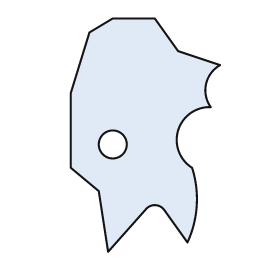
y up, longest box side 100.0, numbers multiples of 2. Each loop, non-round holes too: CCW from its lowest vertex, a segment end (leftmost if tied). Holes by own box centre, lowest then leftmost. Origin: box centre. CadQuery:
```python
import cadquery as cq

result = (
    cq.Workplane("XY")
    .moveTo(-16.0, -50.0)
    .lineTo(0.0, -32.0)
    .threePointArc((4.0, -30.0), (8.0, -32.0))
    .lineTo(18.0, -46.0)
    .threePointArc((22.0, -30.0), (20.0, -14.0))
    .threePointArc((14.0, 2.0), (28.0, 12.0))
    .threePointArc((26.0, 22.0), (32.0, 30.0))
    .lineTo(14.0, 36.0)
    .lineTo(4.0, 50.0)
    .lineTo(-14.0, 50.0)
    .lineTo(-24.0, 44.0)
    .lineTo(-32.0, 18.0)
    .lineTo(-32.0, -14.0)
    .lineTo(-20.0, -24.0)
    .close()
    .moveTo(-14.0, -4.0)
    .circle(6.0)
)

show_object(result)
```